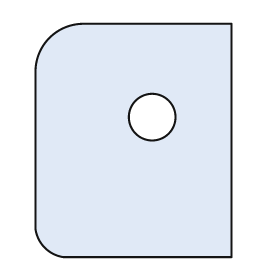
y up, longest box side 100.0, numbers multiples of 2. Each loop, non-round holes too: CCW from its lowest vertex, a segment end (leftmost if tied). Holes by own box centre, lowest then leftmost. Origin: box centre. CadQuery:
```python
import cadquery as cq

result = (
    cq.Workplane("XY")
    .moveTo(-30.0, -50.0)
    .lineTo(42.0, -50.0)
    .lineTo(42.0, 50.0)
    .lineTo(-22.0, 50.0)
    .threePointArc((-36.0, 44.0), (-42.0, 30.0))
    .lineTo(-42.0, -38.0)
    .threePointArc((-38.0, -46.0), (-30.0, -50.0))
    .close()
    .moveTo(8.0, 10.0)
    .circle(10.0)
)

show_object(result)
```